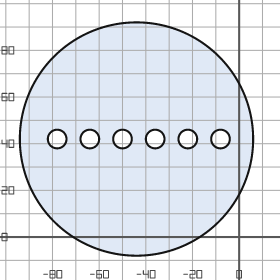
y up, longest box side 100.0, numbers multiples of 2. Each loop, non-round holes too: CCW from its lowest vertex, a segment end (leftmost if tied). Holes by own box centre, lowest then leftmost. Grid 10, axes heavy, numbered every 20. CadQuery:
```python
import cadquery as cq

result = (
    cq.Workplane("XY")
    .moveTo(-44.0, 42.0)
    .circle(50.0)
    .moveTo(-78.0, 42.0)
    .circle(4.0)
    .moveTo(-64.0, 42.0)
    .circle(4.0)
    .moveTo(-50.0, 42.0)
    .circle(4.0)
    .moveTo(-36.0, 42.0)
    .circle(4.0)
    .moveTo(-22.0, 42.0)
    .circle(4.0)
    .moveTo(-8.0, 42.0)
    .circle(4.0)
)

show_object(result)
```